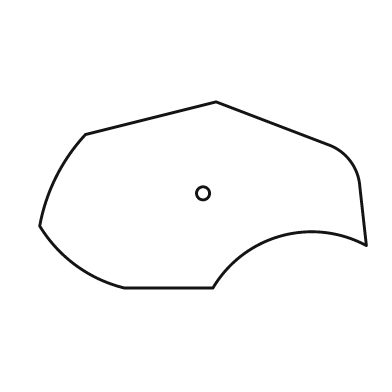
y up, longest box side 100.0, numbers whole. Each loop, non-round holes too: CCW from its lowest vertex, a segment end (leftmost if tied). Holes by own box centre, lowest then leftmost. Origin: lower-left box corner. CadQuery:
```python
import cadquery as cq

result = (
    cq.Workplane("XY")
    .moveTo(26.0, 0.0)
    .lineTo(53.0, 0.0)
    .threePointArc((74.0, 16.0), (100.0, 13.0))
    .lineTo(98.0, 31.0)
    .threePointArc((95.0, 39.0), (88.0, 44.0))
    .lineTo(54.0, 57.0)
    .lineTo(14.0, 47.0)
    .threePointArc((5.0, 34.0), (0.0, 19.0))
    .threePointArc((11.0, 7.0), (26.0, 0.0))
    .close()
    .moveTo(50.0, 29.0)
    .circle(2.0)
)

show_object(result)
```